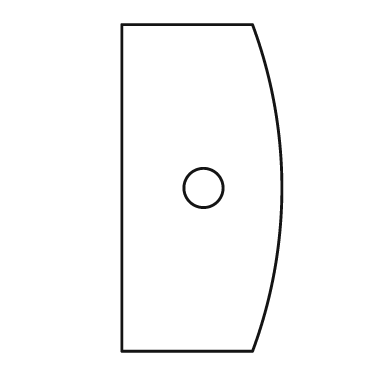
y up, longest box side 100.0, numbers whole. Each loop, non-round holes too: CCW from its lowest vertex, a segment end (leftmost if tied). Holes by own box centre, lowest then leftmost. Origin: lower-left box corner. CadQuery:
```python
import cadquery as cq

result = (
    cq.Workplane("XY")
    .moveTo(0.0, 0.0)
    .lineTo(40.0, 0.0)
    .threePointArc((49.0, 50.0), (40.0, 100.0))
    .lineTo(0.0, 100.0)
    .close()
    .moveTo(25.0, 50.0)
    .circle(6.0)
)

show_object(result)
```